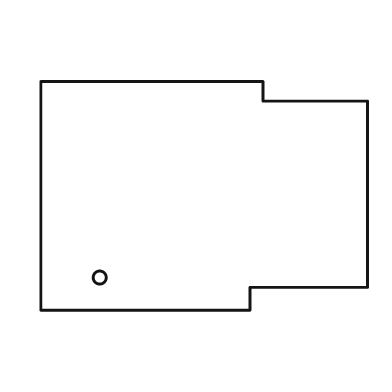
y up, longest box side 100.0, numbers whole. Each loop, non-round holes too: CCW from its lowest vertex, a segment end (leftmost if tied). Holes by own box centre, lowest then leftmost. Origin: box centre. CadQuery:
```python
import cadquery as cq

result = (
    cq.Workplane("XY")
    .moveTo(-50.0, -35.0)
    .lineTo(14.0, -35.0)
    .lineTo(14.0, -28.0)
    .lineTo(50.0, -28.0)
    .lineTo(50.0, 29.0)
    .lineTo(18.0, 29.0)
    .lineTo(18.0, 35.0)
    .lineTo(-50.0, 35.0)
    .close()
    .moveTo(-32.0, -25.0)
    .circle(2.0)
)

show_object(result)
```